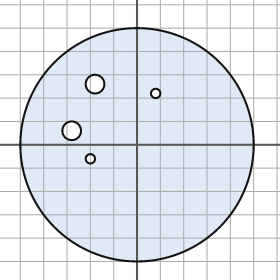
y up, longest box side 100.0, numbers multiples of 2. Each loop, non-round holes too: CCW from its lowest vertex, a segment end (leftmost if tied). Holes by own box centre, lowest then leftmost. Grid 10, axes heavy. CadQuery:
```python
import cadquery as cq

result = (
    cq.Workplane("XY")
    .moveTo(0.0, 0.0)
    .circle(50.0)
    .moveTo(-20.0, -6.0)
    .circle(2.0)
    .moveTo(-28.0, 6.0)
    .circle(4.0)
    .moveTo(8.0, 22.0)
    .circle(2.0)
    .moveTo(-18.0, 26.0)
    .circle(4.0)
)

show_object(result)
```